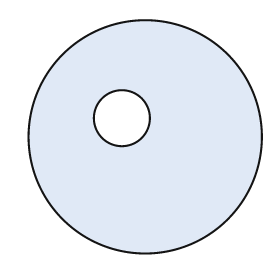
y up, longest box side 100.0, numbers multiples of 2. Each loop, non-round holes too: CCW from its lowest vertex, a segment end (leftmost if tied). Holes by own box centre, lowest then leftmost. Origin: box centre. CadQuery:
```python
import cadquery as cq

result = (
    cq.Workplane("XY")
    .moveTo(0.0, 0.0)
    .circle(50.0)
    .moveTo(-10.0, 8.0)
    .circle(12.0)
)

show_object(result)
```